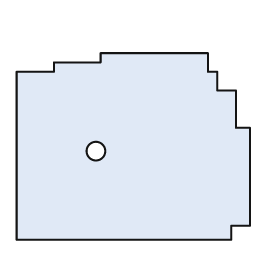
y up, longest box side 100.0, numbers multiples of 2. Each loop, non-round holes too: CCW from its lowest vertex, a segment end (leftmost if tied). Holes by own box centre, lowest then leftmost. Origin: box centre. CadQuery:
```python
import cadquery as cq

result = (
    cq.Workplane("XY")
    .moveTo(-50.0, -40.0)
    .lineTo(42.0, -40.0)
    .lineTo(42.0, -34.0)
    .lineTo(50.0, -34.0)
    .lineTo(50.0, 8.0)
    .lineTo(44.0, 8.0)
    .lineTo(44.0, 24.0)
    .lineTo(36.0, 24.0)
    .lineTo(36.0, 32.0)
    .lineTo(32.0, 32.0)
    .lineTo(32.0, 40.0)
    .lineTo(-14.0, 40.0)
    .lineTo(-14.0, 36.0)
    .lineTo(-34.0, 36.0)
    .lineTo(-34.0, 32.0)
    .lineTo(-50.0, 32.0)
    .close()
    .moveTo(-16.0, -2.0)
    .circle(4.0)
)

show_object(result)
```